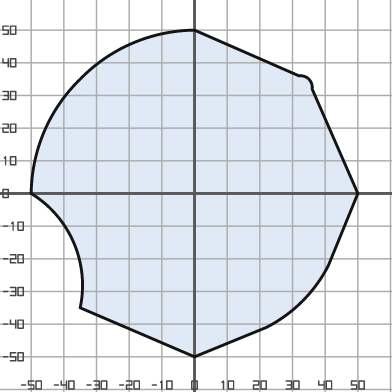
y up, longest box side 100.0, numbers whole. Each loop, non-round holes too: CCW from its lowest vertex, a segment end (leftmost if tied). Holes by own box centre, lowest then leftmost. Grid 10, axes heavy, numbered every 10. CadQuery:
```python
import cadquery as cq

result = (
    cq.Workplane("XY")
    .moveTo(0.0, -50.0)
    .lineTo(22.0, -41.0)
    .threePointArc((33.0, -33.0), (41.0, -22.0))
    .lineTo(50.0, 0.0)
    .lineTo(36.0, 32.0)
    .threePointArc((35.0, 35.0), (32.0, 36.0))
    .lineTo(0.0, 50.0)
    .threePointArc((-19.0, 46.0), (-35.0, 35.0))
    .threePointArc((-46.0, 19.0), (-50.0, 0.0))
    .threePointArc((-37.0, -15.0), (-35.0, -35.0))
    .close()
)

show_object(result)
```